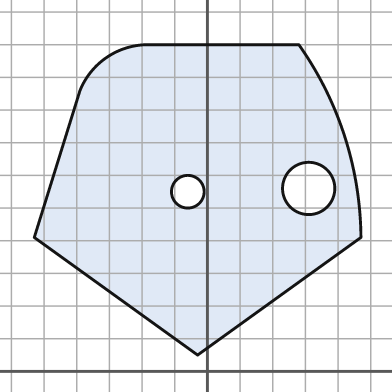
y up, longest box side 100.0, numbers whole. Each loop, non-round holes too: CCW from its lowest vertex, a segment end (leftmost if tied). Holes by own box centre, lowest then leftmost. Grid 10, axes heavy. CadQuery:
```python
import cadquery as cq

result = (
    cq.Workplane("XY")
    .moveTo(-3.0, 5.0)
    .lineTo(47.0, 41.0)
    .threePointArc((42.0, 72.0), (28.0, 100.0))
    .lineTo(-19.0, 100.0)
    .threePointArc((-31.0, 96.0), (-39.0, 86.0))
    .lineTo(-53.0, 41.0)
    .close()
    .moveTo(-6.0, 55.0)
    .circle(5.0)
    .moveTo(31.0, 56.0)
    .circle(8.0)
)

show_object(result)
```